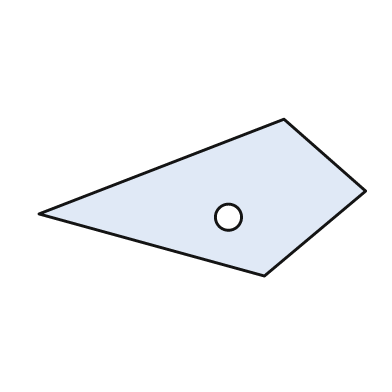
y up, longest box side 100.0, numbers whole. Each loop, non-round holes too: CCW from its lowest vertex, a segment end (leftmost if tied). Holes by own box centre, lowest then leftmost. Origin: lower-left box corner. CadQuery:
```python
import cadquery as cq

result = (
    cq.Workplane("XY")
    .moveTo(69.0, 0.0)
    .lineTo(100.0, 26.0)
    .lineTo(75.0, 48.0)
    .lineTo(0.0, 19.0)
    .close()
    .moveTo(58.0, 18.0)
    .circle(4.0)
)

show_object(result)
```